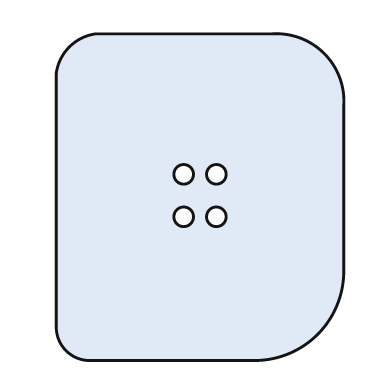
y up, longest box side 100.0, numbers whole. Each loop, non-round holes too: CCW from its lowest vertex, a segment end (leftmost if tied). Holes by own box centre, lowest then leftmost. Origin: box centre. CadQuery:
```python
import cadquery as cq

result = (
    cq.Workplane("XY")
    .moveTo(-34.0, -50.0)
    .lineTo(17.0, -50.0)
    .threePointArc((36.0, -42.0), (44.0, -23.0))
    .lineTo(44.0, 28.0)
    .threePointArc((38.0, 44.0), (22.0, 50.0))
    .lineTo(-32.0, 50.0)
    .threePointArc((-40.0, 46.0), (-44.0, 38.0))
    .lineTo(-44.0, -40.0)
    .threePointArc((-41.0, -47.0), (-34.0, -50.0))
    .close()
    .moveTo(-5.0, -6.0)
    .circle(3.0)
    .moveTo(5.0, -6.0)
    .circle(3.0)
    .moveTo(-5.0, 7.0)
    .circle(3.0)
    .moveTo(5.0, 7.0)
    .circle(3.0)
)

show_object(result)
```